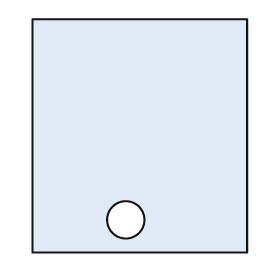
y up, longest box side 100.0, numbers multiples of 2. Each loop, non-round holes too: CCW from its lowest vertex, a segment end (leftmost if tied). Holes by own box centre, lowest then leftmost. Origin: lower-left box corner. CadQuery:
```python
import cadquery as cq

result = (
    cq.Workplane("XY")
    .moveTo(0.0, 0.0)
    .lineTo(92.0, 0.0)
    .lineTo(92.0, 100.0)
    .lineTo(0.0, 100.0)
    .close()
    .moveTo(40.0, 14.0)
    .circle(8.0)
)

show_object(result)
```